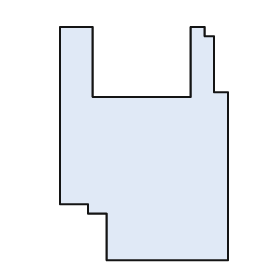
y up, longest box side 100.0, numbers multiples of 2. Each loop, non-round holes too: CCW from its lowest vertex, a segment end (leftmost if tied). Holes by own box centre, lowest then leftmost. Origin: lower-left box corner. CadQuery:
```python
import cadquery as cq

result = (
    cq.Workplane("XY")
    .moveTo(20.0, 0.0)
    .lineTo(72.0, 0.0)
    .lineTo(72.0, 72.0)
    .lineTo(66.0, 72.0)
    .lineTo(66.0, 96.0)
    .lineTo(62.0, 96.0)
    .lineTo(62.0, 100.0)
    .lineTo(56.0, 100.0)
    .lineTo(56.0, 70.0)
    .lineTo(14.0, 70.0)
    .lineTo(14.0, 100.0)
    .lineTo(0.0, 100.0)
    .lineTo(0.0, 24.0)
    .lineTo(12.0, 24.0)
    .lineTo(12.0, 20.0)
    .lineTo(20.0, 20.0)
    .close()
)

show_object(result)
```